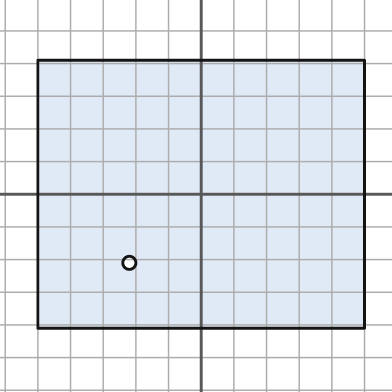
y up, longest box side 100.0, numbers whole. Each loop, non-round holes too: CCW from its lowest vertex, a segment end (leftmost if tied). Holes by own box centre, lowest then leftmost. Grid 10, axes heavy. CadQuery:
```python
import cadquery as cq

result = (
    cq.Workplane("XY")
    .moveTo(-50.0, -41.0)
    .lineTo(50.0, -41.0)
    .lineTo(50.0, 41.0)
    .lineTo(-50.0, 41.0)
    .close()
    .moveTo(-22.0, -21.0)
    .circle(2.0)
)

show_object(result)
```